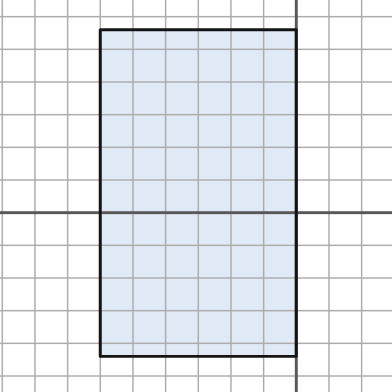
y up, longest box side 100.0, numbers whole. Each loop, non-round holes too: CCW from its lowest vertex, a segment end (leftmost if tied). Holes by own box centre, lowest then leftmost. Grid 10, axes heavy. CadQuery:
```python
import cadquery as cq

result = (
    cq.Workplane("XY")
    .moveTo(-60.0, -44.0)
    .lineTo(0.0, -44.0)
    .lineTo(0.0, 56.0)
    .lineTo(-60.0, 56.0)
    .close()
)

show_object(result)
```